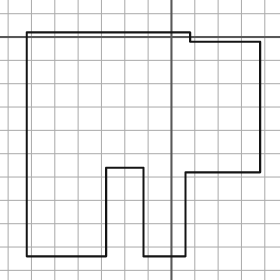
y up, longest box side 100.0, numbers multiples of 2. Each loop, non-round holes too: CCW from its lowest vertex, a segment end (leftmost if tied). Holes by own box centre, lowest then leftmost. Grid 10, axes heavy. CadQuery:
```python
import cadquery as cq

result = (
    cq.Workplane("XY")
    .moveTo(-62.0, -94.0)
    .lineTo(-28.0, -94.0)
    .lineTo(-28.0, -56.0)
    .lineTo(-12.0, -56.0)
    .lineTo(-12.0, -94.0)
    .lineTo(6.0, -94.0)
    .lineTo(6.0, -58.0)
    .lineTo(38.0, -58.0)
    .lineTo(38.0, -2.0)
    .lineTo(8.0, -2.0)
    .lineTo(8.0, 2.0)
    .lineTo(-62.0, 2.0)
    .close()
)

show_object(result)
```